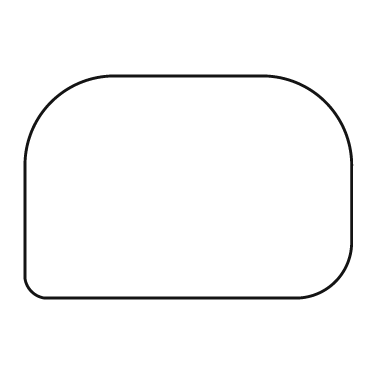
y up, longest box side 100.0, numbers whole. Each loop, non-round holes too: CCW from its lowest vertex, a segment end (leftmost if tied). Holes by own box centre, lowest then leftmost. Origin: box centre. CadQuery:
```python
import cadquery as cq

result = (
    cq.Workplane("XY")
    .moveTo(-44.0, -34.0)
    .lineTo(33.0, -34.0)
    .threePointArc((45.0, -29.0), (50.0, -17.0))
    .lineTo(50.0, 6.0)
    .threePointArc((42.0, 26.0), (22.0, 34.0))
    .lineTo(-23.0, 34.0)
    .threePointArc((-42.0, 26.0), (-50.0, 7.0))
    .lineTo(-50.0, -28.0)
    .threePointArc((-48.0, -32.0), (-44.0, -34.0))
    .close()
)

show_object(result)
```